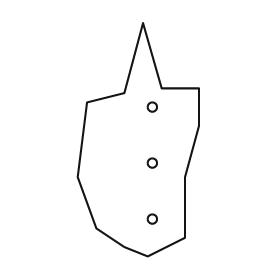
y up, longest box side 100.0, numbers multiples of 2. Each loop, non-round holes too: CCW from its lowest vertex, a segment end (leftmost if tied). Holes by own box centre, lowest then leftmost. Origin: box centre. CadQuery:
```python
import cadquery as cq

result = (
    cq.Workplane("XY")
    .moveTo(4.0, -50.0)
    .lineTo(20.0, -42.0)
    .lineTo(20.0, -16.0)
    .lineTo(26.0, 6.0)
    .lineTo(26.0, 22.0)
    .lineTo(10.0, 22.0)
    .lineTo(2.0, 50.0)
    .lineTo(-6.0, 20.0)
    .lineTo(-22.0, 16.0)
    .lineTo(-26.0, -16.0)
    .lineTo(-18.0, -38.0)
    .lineTo(-6.0, -46.0)
    .close()
    .moveTo(6.0, -34.0)
    .circle(2.0)
    .moveTo(6.0, -10.0)
    .circle(2.0)
    .moveTo(6.0, 14.0)
    .circle(2.0)
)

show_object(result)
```